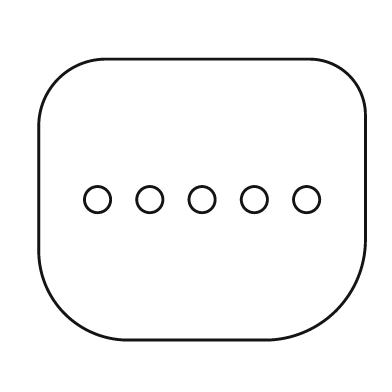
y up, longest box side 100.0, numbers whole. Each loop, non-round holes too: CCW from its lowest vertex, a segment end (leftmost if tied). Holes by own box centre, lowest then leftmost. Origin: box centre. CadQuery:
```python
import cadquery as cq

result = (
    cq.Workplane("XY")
    .moveTo(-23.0, -43.0)
    .lineTo(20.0, -43.0)
    .threePointArc((41.0, -34.0), (50.0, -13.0))
    .lineTo(50.0, 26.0)
    .threePointArc((45.0, 38.0), (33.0, 43.0))
    .lineTo(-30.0, 43.0)
    .threePointArc((-44.0, 37.0), (-50.0, 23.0))
    .lineTo(-50.0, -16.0)
    .threePointArc((-42.0, -35.0), (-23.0, -43.0))
    .close()
    .moveTo(-32.0, 0.0)
    .circle(4.0)
    .moveTo(-16.0, 0.0)
    .circle(4.0)
    .moveTo(0.0, 0.0)
    .circle(4.0)
    .moveTo(16.0, 0.0)
    .circle(4.0)
    .moveTo(32.0, 0.0)
    .circle(4.0)
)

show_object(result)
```